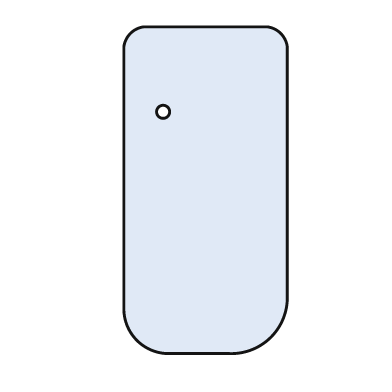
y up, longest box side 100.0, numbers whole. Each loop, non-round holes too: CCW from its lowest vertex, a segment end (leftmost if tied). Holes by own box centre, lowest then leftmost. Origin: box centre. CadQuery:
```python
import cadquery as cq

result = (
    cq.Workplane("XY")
    .moveTo(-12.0, -50.0)
    .lineTo(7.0, -50.0)
    .threePointArc((20.0, -45.0), (25.0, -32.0))
    .lineTo(25.0, 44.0)
    .threePointArc((23.0, 48.0), (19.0, 50.0))
    .lineTo(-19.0, 50.0)
    .threePointArc((-23.0, 48.0), (-25.0, 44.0))
    .lineTo(-25.0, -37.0)
    .threePointArc((-21.0, -46.0), (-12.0, -50.0))
    .close()
    .moveTo(-13.0, 24.0)
    .circle(2.0)
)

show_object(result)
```